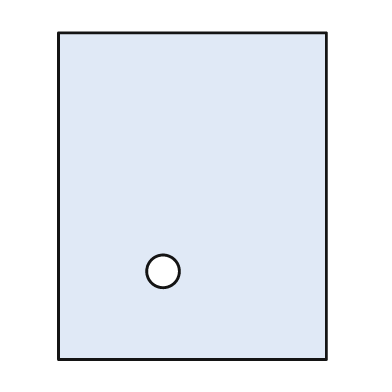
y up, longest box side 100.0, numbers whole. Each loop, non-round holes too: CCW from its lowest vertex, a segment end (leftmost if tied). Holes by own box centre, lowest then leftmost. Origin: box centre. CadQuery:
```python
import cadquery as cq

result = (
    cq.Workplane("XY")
    .moveTo(-41.0, -50.0)
    .lineTo(41.0, -50.0)
    .lineTo(41.0, 50.0)
    .lineTo(-41.0, 50.0)
    .close()
    .moveTo(-9.0, -23.0)
    .circle(5.0)
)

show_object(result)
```